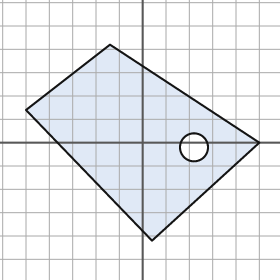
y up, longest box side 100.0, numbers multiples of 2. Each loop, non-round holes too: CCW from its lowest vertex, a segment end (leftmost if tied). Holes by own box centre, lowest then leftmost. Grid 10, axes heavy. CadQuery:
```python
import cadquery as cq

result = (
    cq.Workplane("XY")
    .moveTo(4.0, -42.0)
    .lineTo(50.0, 0.0)
    .lineTo(-14.0, 42.0)
    .lineTo(-50.0, 14.0)
    .close()
    .moveTo(22.0, -2.0)
    .circle(6.0)
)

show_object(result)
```